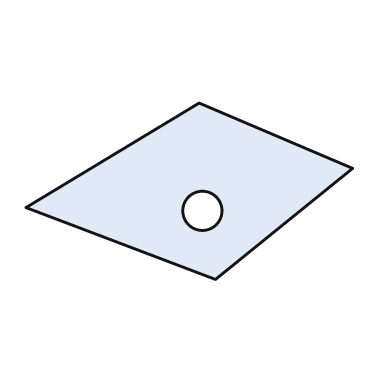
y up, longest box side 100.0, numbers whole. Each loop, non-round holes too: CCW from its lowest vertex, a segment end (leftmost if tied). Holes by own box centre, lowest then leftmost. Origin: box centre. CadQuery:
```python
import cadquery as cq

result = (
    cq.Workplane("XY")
    .moveTo(8.0, -27.0)
    .lineTo(50.0, 7.0)
    .lineTo(3.0, 27.0)
    .lineTo(-50.0, -5.0)
    .close()
    .moveTo(4.0, -6.0)
    .circle(6.0)
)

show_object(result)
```